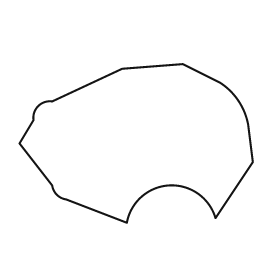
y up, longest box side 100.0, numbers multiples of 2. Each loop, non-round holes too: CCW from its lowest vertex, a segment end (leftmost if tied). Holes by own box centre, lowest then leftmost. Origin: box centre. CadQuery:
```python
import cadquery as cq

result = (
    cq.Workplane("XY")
    .moveTo(-4.0, -34.0)
    .threePointArc((14.0, -18.0), (34.0, -32.0))
    .lineTo(50.0, -8.0)
    .lineTo(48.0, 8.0)
    .threePointArc((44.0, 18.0), (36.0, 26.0))
    .lineTo(20.0, 34.0)
    .lineTo(-6.0, 32.0)
    .lineTo(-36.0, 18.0)
    .threePointArc((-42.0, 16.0), (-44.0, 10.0))
    .lineTo(-50.0, 0.0)
    .lineTo(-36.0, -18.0)
    .threePointArc((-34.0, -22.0), (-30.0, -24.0))
    .close()
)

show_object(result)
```